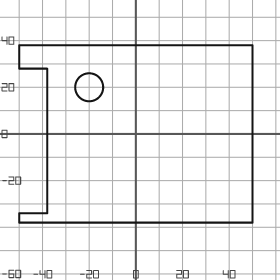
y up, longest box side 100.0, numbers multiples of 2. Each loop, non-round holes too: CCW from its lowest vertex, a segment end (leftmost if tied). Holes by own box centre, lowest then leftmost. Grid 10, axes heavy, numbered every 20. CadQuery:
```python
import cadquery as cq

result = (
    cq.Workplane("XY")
    .moveTo(-50.0, -38.0)
    .lineTo(50.0, -38.0)
    .lineTo(50.0, 38.0)
    .lineTo(-50.0, 38.0)
    .lineTo(-50.0, 28.0)
    .lineTo(-38.0, 28.0)
    .lineTo(-38.0, -34.0)
    .lineTo(-50.0, -34.0)
    .close()
    .moveTo(-20.0, 20.0)
    .circle(6.0)
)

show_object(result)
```